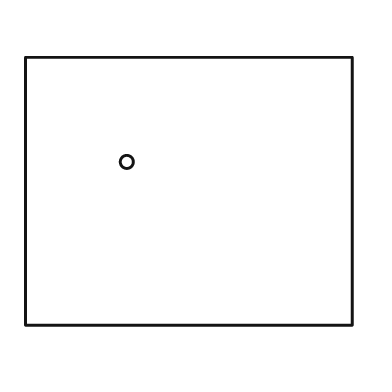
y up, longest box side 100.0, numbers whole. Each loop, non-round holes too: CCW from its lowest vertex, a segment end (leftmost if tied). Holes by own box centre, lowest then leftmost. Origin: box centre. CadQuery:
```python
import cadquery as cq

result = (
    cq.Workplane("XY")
    .moveTo(-50.0, -41.0)
    .lineTo(50.0, -41.0)
    .lineTo(50.0, 41.0)
    .lineTo(-50.0, 41.0)
    .close()
    .moveTo(-19.0, 9.0)
    .circle(2.0)
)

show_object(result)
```